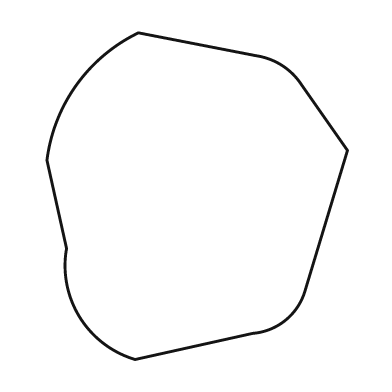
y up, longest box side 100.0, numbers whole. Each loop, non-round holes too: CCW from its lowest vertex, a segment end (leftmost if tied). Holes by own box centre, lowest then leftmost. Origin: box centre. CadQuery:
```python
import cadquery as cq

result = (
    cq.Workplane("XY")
    .moveTo(-19.0, -50.0)
    .lineTo(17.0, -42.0)
    .threePointArc((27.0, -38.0), (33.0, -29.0))
    .lineTo(46.0, 14.0)
    .lineTo(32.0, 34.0)
    .threePointArc((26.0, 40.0), (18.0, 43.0))
    .lineTo(-18.0, 50.0)
    .threePointArc((-37.0, 34.0), (-46.0, 11.0))
    .lineTo(-40.0, -16.0)
    .threePointArc((-36.0, -37.0), (-19.0, -50.0))
    .close()
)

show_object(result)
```